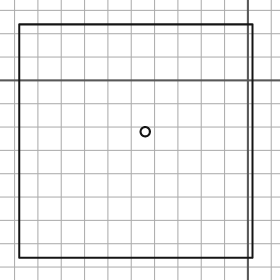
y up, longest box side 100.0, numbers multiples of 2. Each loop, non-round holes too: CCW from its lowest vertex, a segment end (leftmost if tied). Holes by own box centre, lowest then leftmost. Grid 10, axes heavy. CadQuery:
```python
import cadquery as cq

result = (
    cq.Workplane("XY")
    .moveTo(-98.0, -76.0)
    .lineTo(2.0, -76.0)
    .lineTo(2.0, 24.0)
    .lineTo(-98.0, 24.0)
    .close()
    .moveTo(-44.0, -22.0)
    .circle(2.0)
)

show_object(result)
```